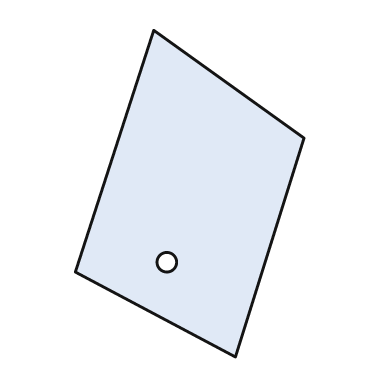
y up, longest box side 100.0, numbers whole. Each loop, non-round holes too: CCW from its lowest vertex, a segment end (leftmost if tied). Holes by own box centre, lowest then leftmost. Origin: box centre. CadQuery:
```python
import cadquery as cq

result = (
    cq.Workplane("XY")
    .moveTo(14.0, -50.0)
    .lineTo(35.0, 17.0)
    .lineTo(-11.0, 50.0)
    .lineTo(-35.0, -24.0)
    .close()
    .moveTo(-7.0, -21.0)
    .circle(3.0)
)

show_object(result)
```